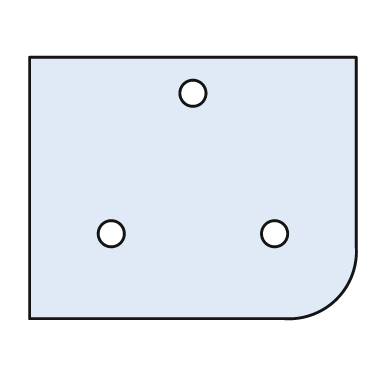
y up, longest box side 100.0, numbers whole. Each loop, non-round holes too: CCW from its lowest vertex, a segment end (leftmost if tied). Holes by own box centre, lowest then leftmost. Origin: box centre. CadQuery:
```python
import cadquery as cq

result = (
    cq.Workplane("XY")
    .moveTo(-50.0, -40.0)
    .lineTo(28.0, -40.0)
    .threePointArc((44.0, -34.0), (50.0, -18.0))
    .lineTo(50.0, 40.0)
    .lineTo(-50.0, 40.0)
    .close()
    .moveTo(-25.0, -14.0)
    .circle(4.0)
    .moveTo(25.0, -14.0)
    .circle(4.0)
    .moveTo(0.0, 29.0)
    .circle(4.0)
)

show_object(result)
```